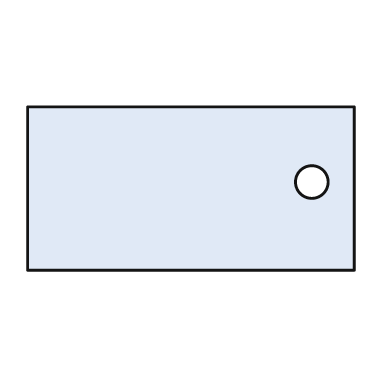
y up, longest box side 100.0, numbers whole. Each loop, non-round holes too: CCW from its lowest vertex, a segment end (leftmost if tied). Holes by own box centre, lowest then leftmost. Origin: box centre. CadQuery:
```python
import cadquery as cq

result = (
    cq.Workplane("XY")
    .moveTo(-50.0, -25.0)
    .lineTo(50.0, -25.0)
    .lineTo(50.0, 25.0)
    .lineTo(-50.0, 25.0)
    .close()
    .moveTo(37.0, 2.0)
    .circle(5.0)
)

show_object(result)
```